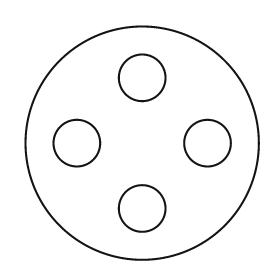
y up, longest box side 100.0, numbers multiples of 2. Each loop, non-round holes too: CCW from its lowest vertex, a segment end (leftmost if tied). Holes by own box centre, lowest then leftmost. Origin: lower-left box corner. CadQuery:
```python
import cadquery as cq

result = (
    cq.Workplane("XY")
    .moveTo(50.0, 50.0)
    .circle(50.0)
    .moveTo(50.0, 22.0)
    .circle(10.0)
    .moveTo(22.0, 50.0)
    .circle(10.0)
    .moveTo(78.0, 50.0)
    .circle(10.0)
    .moveTo(50.0, 78.0)
    .circle(10.0)
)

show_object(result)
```